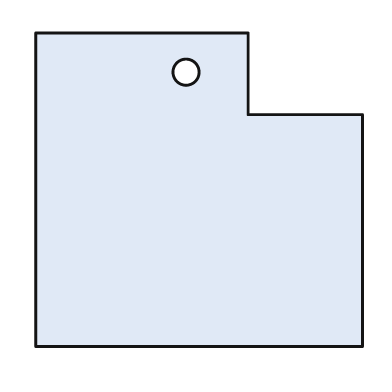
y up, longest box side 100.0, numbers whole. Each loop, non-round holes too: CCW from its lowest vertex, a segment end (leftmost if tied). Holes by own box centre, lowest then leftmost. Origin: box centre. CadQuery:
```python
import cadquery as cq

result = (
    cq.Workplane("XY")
    .moveTo(-50.0, -48.0)
    .lineTo(50.0, -48.0)
    .lineTo(50.0, 23.0)
    .lineTo(15.0, 23.0)
    .lineTo(15.0, 48.0)
    .lineTo(-50.0, 48.0)
    .close()
    .moveTo(-4.0, 36.0)
    .circle(4.0)
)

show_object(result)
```